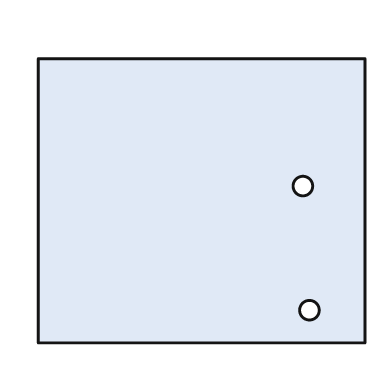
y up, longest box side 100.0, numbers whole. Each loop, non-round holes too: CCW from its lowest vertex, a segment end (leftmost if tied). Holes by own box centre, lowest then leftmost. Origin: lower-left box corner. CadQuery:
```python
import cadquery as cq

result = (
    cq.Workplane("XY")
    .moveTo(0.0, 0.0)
    .lineTo(100.0, 0.0)
    .lineTo(100.0, 87.0)
    .lineTo(0.0, 87.0)
    .close()
    .moveTo(83.0, 10.0)
    .circle(3.0)
    .moveTo(81.0, 48.0)
    .circle(3.0)
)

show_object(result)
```